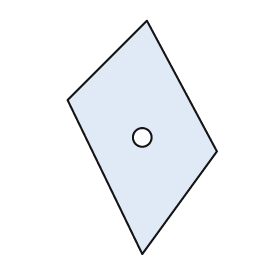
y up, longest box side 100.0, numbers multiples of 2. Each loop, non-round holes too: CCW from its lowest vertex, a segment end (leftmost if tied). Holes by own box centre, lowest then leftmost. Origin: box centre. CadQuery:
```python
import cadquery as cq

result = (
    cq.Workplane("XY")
    .moveTo(0.0, -50.0)
    .lineTo(32.0, -6.0)
    .lineTo(2.0, 50.0)
    .lineTo(-32.0, 16.0)
    .close()
    .moveTo(0.0, 0.0)
    .circle(4.0)
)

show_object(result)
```